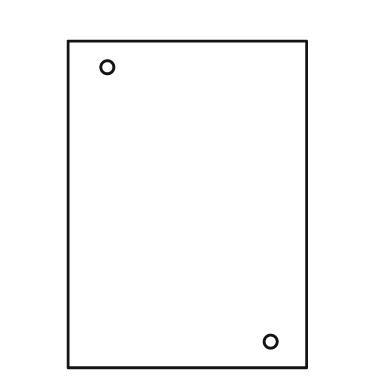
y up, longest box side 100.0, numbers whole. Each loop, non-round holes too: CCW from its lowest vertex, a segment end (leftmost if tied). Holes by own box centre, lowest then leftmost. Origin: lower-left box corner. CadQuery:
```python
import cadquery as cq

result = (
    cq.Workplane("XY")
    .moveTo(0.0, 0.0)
    .lineTo(73.0, 0.0)
    .lineTo(73.0, 100.0)
    .lineTo(0.0, 100.0)
    .close()
    .moveTo(62.0, 8.0)
    .circle(2.0)
    .moveTo(12.0, 92.0)
    .circle(2.0)
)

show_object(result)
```